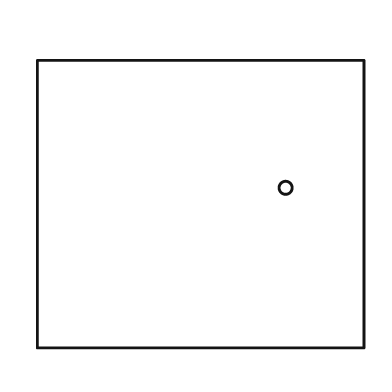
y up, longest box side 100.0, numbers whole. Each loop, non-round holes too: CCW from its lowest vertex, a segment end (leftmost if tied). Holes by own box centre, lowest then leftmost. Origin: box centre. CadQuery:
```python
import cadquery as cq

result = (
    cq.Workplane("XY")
    .moveTo(-50.0, -44.0)
    .lineTo(50.0, -44.0)
    .lineTo(50.0, 44.0)
    .lineTo(-50.0, 44.0)
    .close()
    .moveTo(26.0, 5.0)
    .circle(2.0)
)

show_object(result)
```